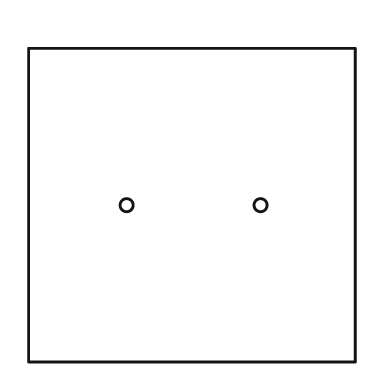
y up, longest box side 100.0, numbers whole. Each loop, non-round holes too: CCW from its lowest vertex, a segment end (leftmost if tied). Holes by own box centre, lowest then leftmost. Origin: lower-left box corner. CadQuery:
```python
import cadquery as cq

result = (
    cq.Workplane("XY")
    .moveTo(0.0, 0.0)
    .lineTo(100.0, 0.0)
    .lineTo(100.0, 96.0)
    .lineTo(0.0, 96.0)
    .close()
    .moveTo(30.0, 48.0)
    .circle(2.0)
    .moveTo(71.0, 48.0)
    .circle(2.0)
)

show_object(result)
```